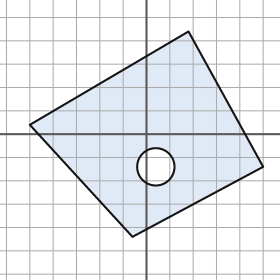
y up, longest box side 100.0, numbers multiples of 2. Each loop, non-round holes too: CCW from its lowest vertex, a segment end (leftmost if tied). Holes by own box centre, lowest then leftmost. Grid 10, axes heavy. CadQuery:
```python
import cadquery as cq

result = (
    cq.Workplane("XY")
    .moveTo(-6.0, -44.0)
    .lineTo(50.0, -14.0)
    .lineTo(18.0, 44.0)
    .lineTo(-50.0, 4.0)
    .close()
    .moveTo(4.0, -14.0)
    .circle(8.0)
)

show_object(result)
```